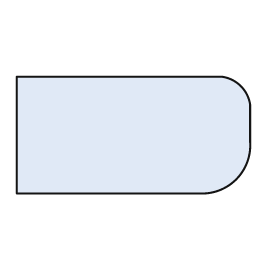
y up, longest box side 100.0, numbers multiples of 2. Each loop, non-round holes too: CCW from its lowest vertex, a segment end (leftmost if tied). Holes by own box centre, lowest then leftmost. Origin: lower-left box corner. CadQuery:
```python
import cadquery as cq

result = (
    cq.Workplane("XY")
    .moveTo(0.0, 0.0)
    .lineTo(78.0, 0.0)
    .threePointArc((94.0, 6.0), (100.0, 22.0))
    .lineTo(100.0, 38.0)
    .threePointArc((96.0, 46.0), (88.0, 50.0))
    .lineTo(0.0, 50.0)
    .close()
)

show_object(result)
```